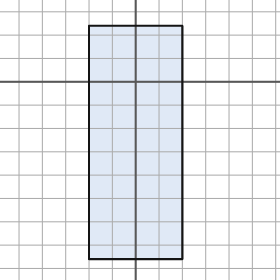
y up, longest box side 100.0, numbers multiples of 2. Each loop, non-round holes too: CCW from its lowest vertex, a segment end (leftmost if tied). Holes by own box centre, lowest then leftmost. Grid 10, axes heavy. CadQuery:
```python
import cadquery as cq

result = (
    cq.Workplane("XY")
    .moveTo(-20.0, -76.0)
    .lineTo(20.0, -76.0)
    .lineTo(20.0, 24.0)
    .lineTo(-20.0, 24.0)
    .close()
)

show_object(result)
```